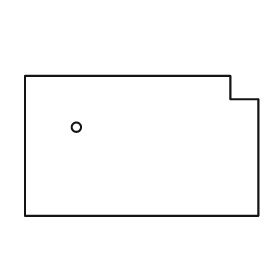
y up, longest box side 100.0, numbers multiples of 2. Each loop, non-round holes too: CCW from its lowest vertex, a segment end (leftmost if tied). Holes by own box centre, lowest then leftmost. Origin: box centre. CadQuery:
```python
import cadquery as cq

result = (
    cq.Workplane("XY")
    .moveTo(-50.0, -30.0)
    .lineTo(50.0, -30.0)
    .lineTo(50.0, 20.0)
    .lineTo(38.0, 20.0)
    .lineTo(38.0, 30.0)
    .lineTo(-50.0, 30.0)
    .close()
    .moveTo(-28.0, 8.0)
    .circle(2.0)
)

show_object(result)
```